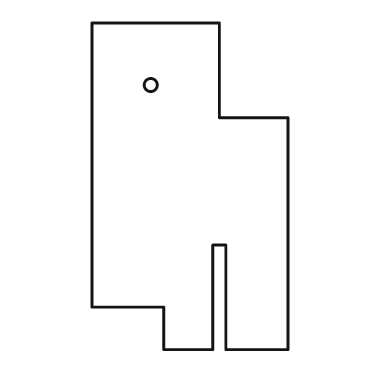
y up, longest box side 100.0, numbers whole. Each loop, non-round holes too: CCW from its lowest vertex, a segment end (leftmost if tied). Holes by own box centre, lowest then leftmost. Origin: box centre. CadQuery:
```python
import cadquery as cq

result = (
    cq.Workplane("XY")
    .moveTo(-8.0, -50.0)
    .lineTo(7.0, -50.0)
    .lineTo(7.0, -18.0)
    .lineTo(11.0, -18.0)
    .lineTo(11.0, -50.0)
    .lineTo(30.0, -50.0)
    .lineTo(30.0, 21.0)
    .lineTo(9.0, 21.0)
    .lineTo(9.0, 50.0)
    .lineTo(-30.0, 50.0)
    .lineTo(-30.0, -37.0)
    .lineTo(-8.0, -37.0)
    .close()
    .moveTo(-12.0, 31.0)
    .circle(2.0)
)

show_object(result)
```